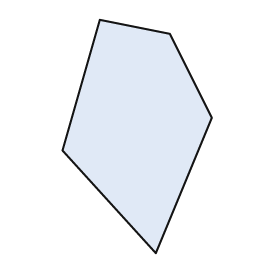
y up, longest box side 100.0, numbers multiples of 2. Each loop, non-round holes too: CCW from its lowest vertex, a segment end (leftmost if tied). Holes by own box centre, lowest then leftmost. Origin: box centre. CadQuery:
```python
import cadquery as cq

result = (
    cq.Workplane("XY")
    .moveTo(8.0, -50.0)
    .lineTo(32.0, 8.0)
    .lineTo(14.0, 44.0)
    .lineTo(-16.0, 50.0)
    .lineTo(-32.0, -6.0)
    .close()
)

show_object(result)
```